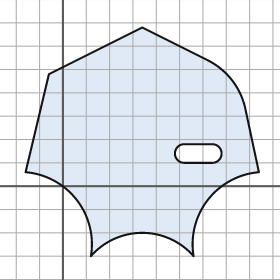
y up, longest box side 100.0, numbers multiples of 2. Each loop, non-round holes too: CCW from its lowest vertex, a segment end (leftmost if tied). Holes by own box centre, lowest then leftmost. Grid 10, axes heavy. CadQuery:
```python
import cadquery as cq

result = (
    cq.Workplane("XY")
    .moveTo(12.0, -30.0)
    .threePointArc((34.0, -20.0), (56.0, -30.0))
    .threePointArc((62.0, -6.0), (84.0, 6.0))
    .lineTo(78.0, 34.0)
    .threePointArc((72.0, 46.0), (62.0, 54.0))
    .lineTo(34.0, 68.0)
    .lineTo(-6.0, 48.0)
    .lineTo(-16.0, 6.0)
    .threePointArc((6.0, -6.0), (12.0, -30.0))
    .close()
    .moveTo(52.0, 10.0)
    .lineTo(64.0, 10.0)
    .threePointArc((68.0, 14.0), (64.0, 18.0))
    .lineTo(52.0, 18.0)
    .threePointArc((48.0, 14.0), (52.0, 10.0))
    .close()
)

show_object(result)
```